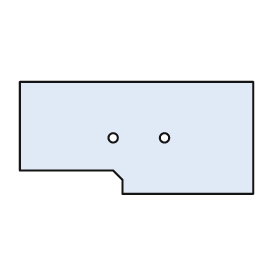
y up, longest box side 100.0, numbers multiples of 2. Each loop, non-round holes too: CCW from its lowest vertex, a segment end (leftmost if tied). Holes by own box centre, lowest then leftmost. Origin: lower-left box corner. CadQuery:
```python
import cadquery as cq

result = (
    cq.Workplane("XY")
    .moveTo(44.0, 0.0)
    .lineTo(100.0, 0.0)
    .lineTo(100.0, 48.0)
    .lineTo(0.0, 48.0)
    .lineTo(0.0, 10.0)
    .lineTo(40.0, 10.0)
    .lineTo(44.0, 6.0)
    .close()
    .moveTo(40.0, 24.0)
    .circle(2.0)
    .moveTo(62.0, 24.0)
    .circle(2.0)
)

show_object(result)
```